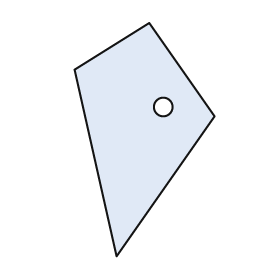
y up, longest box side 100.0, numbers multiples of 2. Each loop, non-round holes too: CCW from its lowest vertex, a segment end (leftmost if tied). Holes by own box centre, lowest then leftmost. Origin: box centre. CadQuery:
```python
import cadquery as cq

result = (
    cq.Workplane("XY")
    .moveTo(-12.0, -50.0)
    .lineTo(30.0, 10.0)
    .lineTo(2.0, 50.0)
    .lineTo(-30.0, 30.0)
    .close()
    .moveTo(8.0, 14.0)
    .circle(4.0)
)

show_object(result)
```